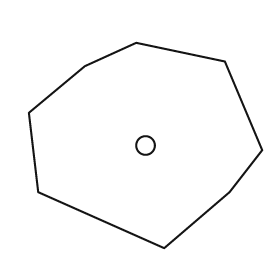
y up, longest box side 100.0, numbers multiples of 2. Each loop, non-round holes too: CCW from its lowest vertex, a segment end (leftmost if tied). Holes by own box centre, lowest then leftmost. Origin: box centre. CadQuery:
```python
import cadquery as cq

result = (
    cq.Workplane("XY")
    .moveTo(8.0, -44.0)
    .lineTo(36.0, -20.0)
    .lineTo(50.0, -2.0)
    .lineTo(34.0, 36.0)
    .lineTo(-4.0, 44.0)
    .lineTo(-26.0, 34.0)
    .lineTo(-50.0, 14.0)
    .lineTo(-46.0, -20.0)
    .close()
    .moveTo(0.0, 0.0)
    .circle(4.0)
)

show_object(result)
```